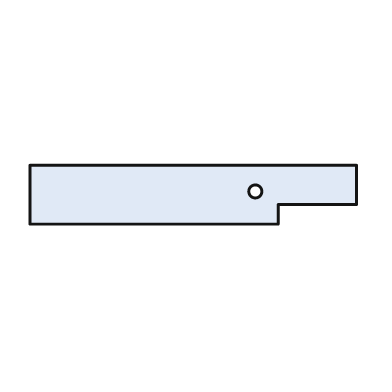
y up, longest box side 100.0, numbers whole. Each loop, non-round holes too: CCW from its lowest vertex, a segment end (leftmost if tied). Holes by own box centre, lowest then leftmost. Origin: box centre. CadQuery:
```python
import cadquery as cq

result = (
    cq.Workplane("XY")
    .moveTo(-50.0, -9.0)
    .lineTo(26.0, -9.0)
    .lineTo(26.0, -3.0)
    .lineTo(50.0, -3.0)
    .lineTo(50.0, 9.0)
    .lineTo(-50.0, 9.0)
    .close()
    .moveTo(19.0, 1.0)
    .circle(2.0)
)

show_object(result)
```